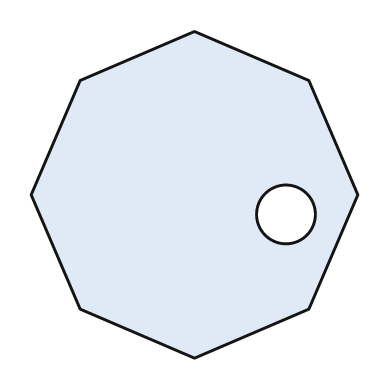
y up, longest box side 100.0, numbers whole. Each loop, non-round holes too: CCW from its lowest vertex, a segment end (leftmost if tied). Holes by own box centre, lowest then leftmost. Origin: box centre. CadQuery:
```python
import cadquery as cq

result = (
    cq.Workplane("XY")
    .moveTo(0.0, -50.0)
    .lineTo(35.0, -35.0)
    .lineTo(50.0, 0.0)
    .lineTo(35.0, 35.0)
    .lineTo(0.0, 50.0)
    .lineTo(-35.0, 35.0)
    .lineTo(-50.0, 0.0)
    .lineTo(-35.0, -35.0)
    .close()
    .moveTo(28.0, -6.0)
    .circle(9.0)
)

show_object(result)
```